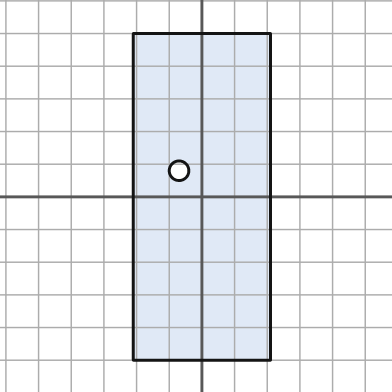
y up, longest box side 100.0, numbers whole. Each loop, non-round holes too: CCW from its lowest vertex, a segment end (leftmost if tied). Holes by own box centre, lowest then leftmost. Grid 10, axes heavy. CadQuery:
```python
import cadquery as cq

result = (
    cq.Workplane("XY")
    .moveTo(-21.0, -50.0)
    .lineTo(21.0, -50.0)
    .lineTo(21.0, 50.0)
    .lineTo(-21.0, 50.0)
    .close()
    .moveTo(-7.0, 8.0)
    .circle(3.0)
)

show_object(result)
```